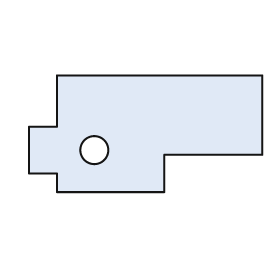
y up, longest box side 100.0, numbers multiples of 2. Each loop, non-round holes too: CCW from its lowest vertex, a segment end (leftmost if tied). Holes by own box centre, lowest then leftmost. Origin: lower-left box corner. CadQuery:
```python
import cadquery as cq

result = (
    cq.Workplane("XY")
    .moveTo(12.0, 0.0)
    .lineTo(58.0, 0.0)
    .lineTo(58.0, 16.0)
    .lineTo(100.0, 16.0)
    .lineTo(100.0, 50.0)
    .lineTo(12.0, 50.0)
    .lineTo(12.0, 28.0)
    .lineTo(0.0, 28.0)
    .lineTo(0.0, 8.0)
    .lineTo(12.0, 8.0)
    .close()
    .moveTo(28.0, 18.0)
    .circle(6.0)
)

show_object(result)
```